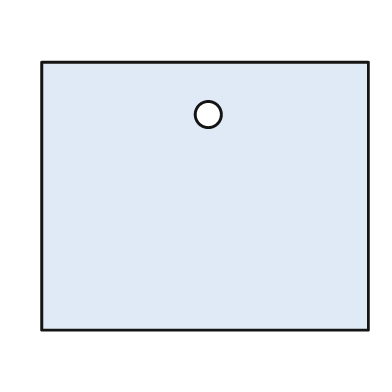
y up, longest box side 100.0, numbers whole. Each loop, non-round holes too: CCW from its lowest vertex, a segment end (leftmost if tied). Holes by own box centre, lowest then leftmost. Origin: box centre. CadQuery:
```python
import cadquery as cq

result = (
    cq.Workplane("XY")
    .moveTo(-50.0, -41.0)
    .lineTo(50.0, -41.0)
    .lineTo(50.0, 41.0)
    .lineTo(-50.0, 41.0)
    .close()
    .moveTo(1.0, 25.0)
    .circle(4.0)
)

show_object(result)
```